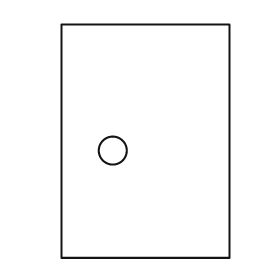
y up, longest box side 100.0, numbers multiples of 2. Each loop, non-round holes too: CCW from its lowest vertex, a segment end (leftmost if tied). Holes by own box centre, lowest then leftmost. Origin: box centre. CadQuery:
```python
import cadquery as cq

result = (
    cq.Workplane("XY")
    .moveTo(-36.0, -50.0)
    .lineTo(36.0, -50.0)
    .lineTo(36.0, 50.0)
    .lineTo(-36.0, 50.0)
    .close()
    .moveTo(-14.0, -4.0)
    .circle(6.0)
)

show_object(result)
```